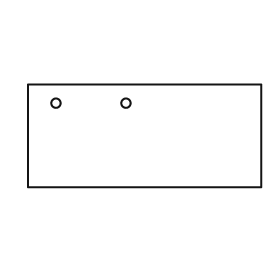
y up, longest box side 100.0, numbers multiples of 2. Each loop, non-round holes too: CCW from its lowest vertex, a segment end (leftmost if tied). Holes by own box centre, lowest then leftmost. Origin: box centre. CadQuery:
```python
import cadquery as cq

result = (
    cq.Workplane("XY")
    .moveTo(-50.0, -22.0)
    .lineTo(50.0, -22.0)
    .lineTo(50.0, 22.0)
    .lineTo(-50.0, 22.0)
    .close()
    .moveTo(-38.0, 14.0)
    .circle(2.0)
    .moveTo(-8.0, 14.0)
    .circle(2.0)
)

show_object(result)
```